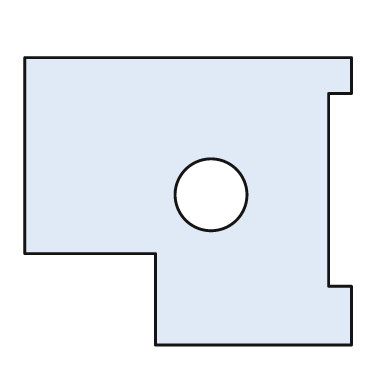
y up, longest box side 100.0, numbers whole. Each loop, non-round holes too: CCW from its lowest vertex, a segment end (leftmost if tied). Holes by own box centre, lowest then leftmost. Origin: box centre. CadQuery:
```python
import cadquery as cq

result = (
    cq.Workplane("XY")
    .moveTo(-10.0, -44.0)
    .lineTo(50.0, -44.0)
    .lineTo(50.0, -26.0)
    .lineTo(43.0, -26.0)
    .lineTo(43.0, 33.0)
    .lineTo(50.0, 33.0)
    .lineTo(50.0, 44.0)
    .lineTo(-50.0, 44.0)
    .lineTo(-50.0, -16.0)
    .lineTo(-10.0, -16.0)
    .close()
    .moveTo(7.0, 2.0)
    .circle(11.0)
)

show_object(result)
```